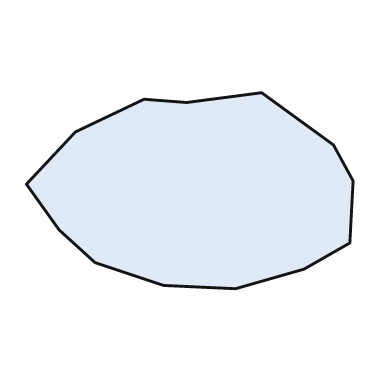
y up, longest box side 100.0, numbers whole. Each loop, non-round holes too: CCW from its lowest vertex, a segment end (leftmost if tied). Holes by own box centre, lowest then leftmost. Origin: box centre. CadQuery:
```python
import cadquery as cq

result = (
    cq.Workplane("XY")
    .moveTo(14.0, -30.0)
    .lineTo(35.0, -24.0)
    .lineTo(49.0, -16.0)
    .lineTo(50.0, 3.0)
    .lineTo(44.0, 14.0)
    .lineTo(22.0, 30.0)
    .lineTo(-1.0, 27.0)
    .lineTo(-14.0, 28.0)
    .lineTo(-35.0, 18.0)
    .lineTo(-50.0, 2.0)
    .lineTo(-40.0, -12.0)
    .lineTo(-29.0, -22.0)
    .lineTo(-8.0, -29.0)
    .close()
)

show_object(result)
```